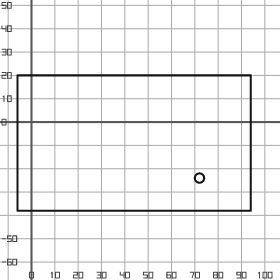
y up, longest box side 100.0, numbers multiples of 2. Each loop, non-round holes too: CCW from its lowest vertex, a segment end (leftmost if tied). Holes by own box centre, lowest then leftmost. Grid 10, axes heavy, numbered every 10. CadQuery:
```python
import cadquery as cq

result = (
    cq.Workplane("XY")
    .moveTo(-6.0, -38.0)
    .lineTo(94.0, -38.0)
    .lineTo(94.0, 20.0)
    .lineTo(-6.0, 20.0)
    .close()
    .moveTo(72.0, -24.0)
    .circle(2.0)
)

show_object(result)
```